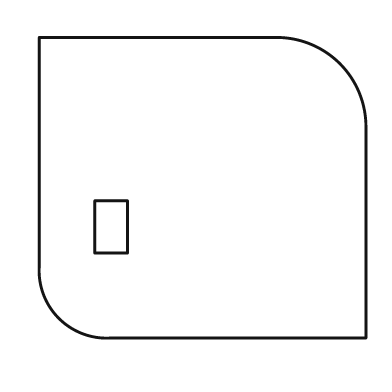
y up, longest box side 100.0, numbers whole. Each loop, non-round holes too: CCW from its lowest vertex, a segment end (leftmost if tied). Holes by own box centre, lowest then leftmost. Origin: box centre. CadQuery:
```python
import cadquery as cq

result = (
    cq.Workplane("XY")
    .moveTo(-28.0, -46.0)
    .lineTo(50.0, -46.0)
    .lineTo(50.0, 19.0)
    .threePointArc((42.0, 38.0), (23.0, 46.0))
    .lineTo(-50.0, 46.0)
    .lineTo(-50.0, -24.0)
    .threePointArc((-44.0, -40.0), (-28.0, -46.0))
    .close()
    .moveTo(-33.0, -20.0)
    .lineTo(-23.0, -20.0)
    .lineTo(-23.0, -4.0)
    .lineTo(-33.0, -4.0)
    .close()
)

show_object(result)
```